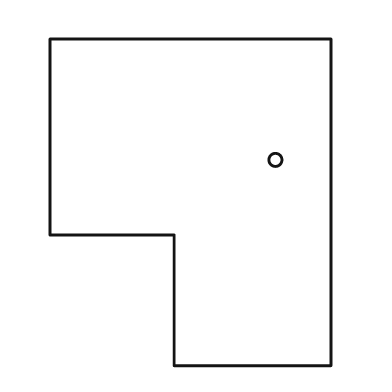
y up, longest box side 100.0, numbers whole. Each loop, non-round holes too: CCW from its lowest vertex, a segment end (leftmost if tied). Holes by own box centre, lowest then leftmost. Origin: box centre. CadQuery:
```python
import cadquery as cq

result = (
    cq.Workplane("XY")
    .moveTo(-5.0, -50.0)
    .lineTo(43.0, -50.0)
    .lineTo(43.0, 50.0)
    .lineTo(-43.0, 50.0)
    .lineTo(-43.0, -10.0)
    .lineTo(-5.0, -10.0)
    .close()
    .moveTo(26.0, 13.0)
    .circle(2.0)
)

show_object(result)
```